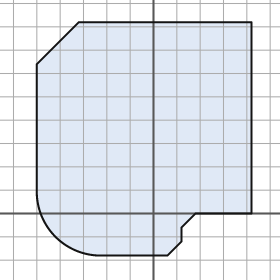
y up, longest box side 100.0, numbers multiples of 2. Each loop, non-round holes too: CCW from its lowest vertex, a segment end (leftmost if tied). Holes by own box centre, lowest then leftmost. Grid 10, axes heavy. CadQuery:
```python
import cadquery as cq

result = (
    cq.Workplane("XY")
    .moveTo(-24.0, -18.0)
    .lineTo(6.0, -18.0)
    .lineTo(12.0, -12.0)
    .lineTo(12.0, -6.0)
    .lineTo(18.0, 0.0)
    .lineTo(42.0, 0.0)
    .lineTo(42.0, 82.0)
    .lineTo(-32.0, 82.0)
    .lineTo(-50.0, 64.0)
    .lineTo(-50.0, 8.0)
    .threePointArc((-42.0, -10.0), (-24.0, -18.0))
    .close()
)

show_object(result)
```